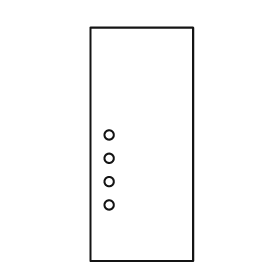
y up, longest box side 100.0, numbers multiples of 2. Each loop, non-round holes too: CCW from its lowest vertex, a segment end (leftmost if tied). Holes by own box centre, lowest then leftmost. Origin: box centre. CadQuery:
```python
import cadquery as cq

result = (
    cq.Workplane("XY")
    .moveTo(-22.0, -50.0)
    .lineTo(22.0, -50.0)
    .lineTo(22.0, 50.0)
    .lineTo(-22.0, 50.0)
    .close()
    .moveTo(-14.0, -26.0)
    .circle(2.0)
    .moveTo(-14.0, -16.0)
    .circle(2.0)
    .moveTo(-14.0, -6.0)
    .circle(2.0)
    .moveTo(-14.0, 4.0)
    .circle(2.0)
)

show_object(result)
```